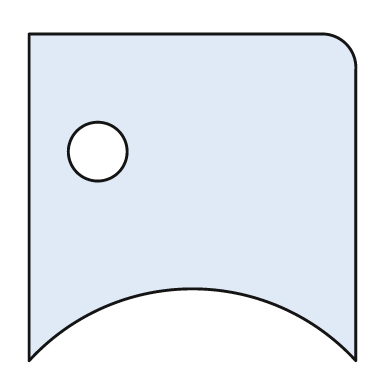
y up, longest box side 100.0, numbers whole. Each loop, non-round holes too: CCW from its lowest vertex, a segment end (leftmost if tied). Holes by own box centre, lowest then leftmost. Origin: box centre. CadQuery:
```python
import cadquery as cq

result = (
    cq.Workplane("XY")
    .moveTo(-50.0, -50.0)
    .threePointArc((0.0, -28.0), (50.0, -50.0))
    .lineTo(50.0, 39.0)
    .threePointArc((47.0, 47.0), (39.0, 50.0))
    .lineTo(-50.0, 50.0)
    .close()
    .moveTo(-29.0, 14.0)
    .circle(9.0)
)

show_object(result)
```